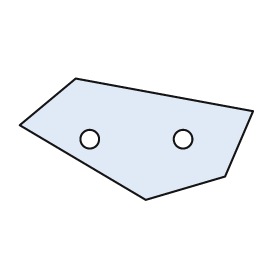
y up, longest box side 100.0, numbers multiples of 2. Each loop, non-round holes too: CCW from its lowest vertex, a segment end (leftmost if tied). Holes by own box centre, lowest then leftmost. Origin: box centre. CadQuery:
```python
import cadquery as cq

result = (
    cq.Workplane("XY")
    .moveTo(4.0, -26.0)
    .lineTo(38.0, -16.0)
    .lineTo(50.0, 12.0)
    .lineTo(-26.0, 26.0)
    .lineTo(-50.0, 6.0)
    .close()
    .moveTo(-20.0, 0.0)
    .circle(4.0)
    .moveTo(20.0, 0.0)
    .circle(4.0)
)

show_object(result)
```